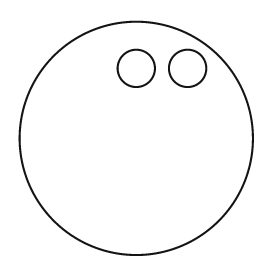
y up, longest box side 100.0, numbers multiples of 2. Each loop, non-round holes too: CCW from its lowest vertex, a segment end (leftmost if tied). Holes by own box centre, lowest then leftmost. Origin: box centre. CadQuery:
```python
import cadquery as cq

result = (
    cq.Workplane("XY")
    .moveTo(0.0, 0.0)
    .circle(50.0)
    .moveTo(0.0, 30.0)
    .circle(8.0)
    .moveTo(22.0, 30.0)
    .circle(8.0)
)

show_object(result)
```